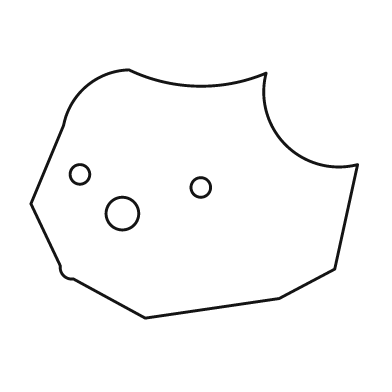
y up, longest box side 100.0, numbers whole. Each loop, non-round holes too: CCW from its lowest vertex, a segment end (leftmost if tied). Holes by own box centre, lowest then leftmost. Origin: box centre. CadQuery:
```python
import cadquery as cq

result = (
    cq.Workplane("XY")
    .moveTo(-15.0, -38.0)
    .lineTo(26.0, -32.0)
    .lineTo(43.0, -23.0)
    .lineTo(50.0, 9.0)
    .threePointArc((28.0, 15.0), (22.0, 37.0))
    .threePointArc((1.0, 33.0), (-20.0, 38.0))
    .threePointArc((-33.0, 33.0), (-40.0, 21.0))
    .lineTo(-50.0, -3.0)
    .lineTo(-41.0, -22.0)
    .threePointArc((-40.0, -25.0), (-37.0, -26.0))
    .close()
    .moveTo(-22.0, -6.0)
    .circle(5.0)
    .moveTo(2.0, 2.0)
    .circle(3.0)
    .moveTo(-35.0, 6.0)
    .circle(3.0)
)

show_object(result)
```